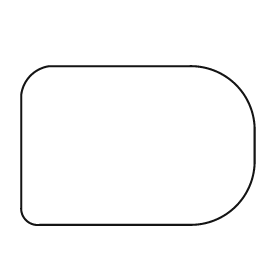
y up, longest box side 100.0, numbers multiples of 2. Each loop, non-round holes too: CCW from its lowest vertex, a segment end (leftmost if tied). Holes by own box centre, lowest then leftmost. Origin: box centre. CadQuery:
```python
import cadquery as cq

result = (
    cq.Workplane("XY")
    .moveTo(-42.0, -34.0)
    .lineTo(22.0, -34.0)
    .threePointArc((42.0, -26.0), (50.0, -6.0))
    .lineTo(50.0, 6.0)
    .threePointArc((42.0, 26.0), (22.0, 34.0))
    .lineTo(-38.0, 34.0)
    .threePointArc((-46.0, 30.0), (-50.0, 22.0))
    .lineTo(-50.0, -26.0)
    .threePointArc((-48.0, -32.0), (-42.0, -34.0))
    .close()
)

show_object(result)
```